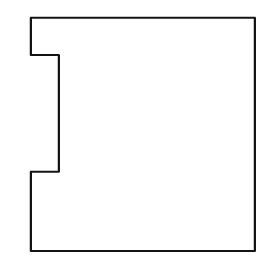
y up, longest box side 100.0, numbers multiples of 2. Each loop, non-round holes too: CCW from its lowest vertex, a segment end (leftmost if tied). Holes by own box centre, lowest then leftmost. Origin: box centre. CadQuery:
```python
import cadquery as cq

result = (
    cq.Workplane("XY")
    .moveTo(-48.0, -50.0)
    .lineTo(48.0, -50.0)
    .lineTo(48.0, 50.0)
    .lineTo(-48.0, 50.0)
    .lineTo(-48.0, 34.0)
    .lineTo(-36.0, 34.0)
    .lineTo(-36.0, -16.0)
    .lineTo(-48.0, -16.0)
    .close()
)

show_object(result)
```